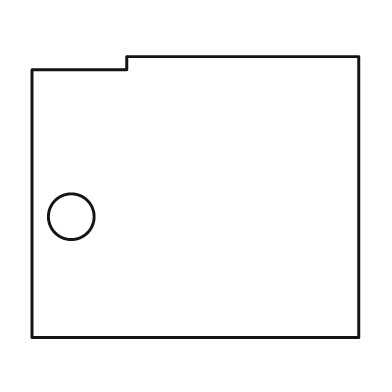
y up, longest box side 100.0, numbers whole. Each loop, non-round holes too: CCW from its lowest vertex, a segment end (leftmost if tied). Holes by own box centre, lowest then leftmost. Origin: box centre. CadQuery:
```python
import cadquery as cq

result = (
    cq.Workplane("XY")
    .moveTo(-50.0, -43.0)
    .lineTo(50.0, -43.0)
    .lineTo(50.0, 43.0)
    .lineTo(-21.0, 43.0)
    .lineTo(-21.0, 39.0)
    .lineTo(-50.0, 39.0)
    .close()
    .moveTo(-38.0, -6.0)
    .circle(7.0)
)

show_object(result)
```